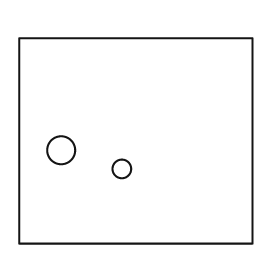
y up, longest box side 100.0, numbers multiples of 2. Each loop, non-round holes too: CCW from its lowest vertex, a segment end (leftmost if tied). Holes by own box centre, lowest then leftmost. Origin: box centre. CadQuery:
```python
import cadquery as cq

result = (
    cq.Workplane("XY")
    .moveTo(-50.0, -44.0)
    .lineTo(50.0, -44.0)
    .lineTo(50.0, 44.0)
    .lineTo(-50.0, 44.0)
    .close()
    .moveTo(-6.0, -12.0)
    .circle(4.0)
    .moveTo(-32.0, -4.0)
    .circle(6.0)
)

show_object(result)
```